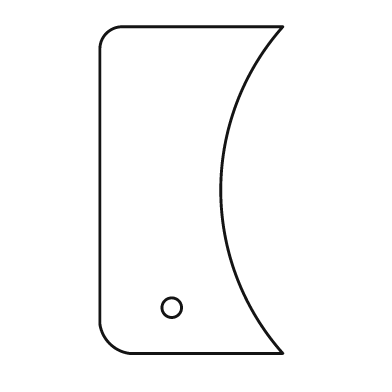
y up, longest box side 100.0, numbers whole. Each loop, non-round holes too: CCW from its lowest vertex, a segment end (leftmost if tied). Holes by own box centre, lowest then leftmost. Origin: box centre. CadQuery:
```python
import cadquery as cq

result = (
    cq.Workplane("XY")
    .moveTo(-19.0, -50.0)
    .lineTo(28.0, -50.0)
    .threePointArc((9.0, 0.0), (28.0, 50.0))
    .lineTo(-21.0, 50.0)
    .threePointArc((-26.0, 48.0), (-28.0, 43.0))
    .lineTo(-28.0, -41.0)
    .threePointArc((-25.0, -47.0), (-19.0, -50.0))
    .close()
    .moveTo(-6.0, -36.0)
    .circle(3.0)
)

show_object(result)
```